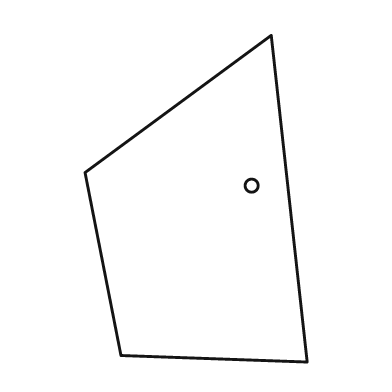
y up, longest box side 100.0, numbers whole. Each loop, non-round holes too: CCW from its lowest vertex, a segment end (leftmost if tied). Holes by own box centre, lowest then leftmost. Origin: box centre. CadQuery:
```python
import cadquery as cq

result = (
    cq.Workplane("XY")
    .moveTo(34.0, -50.0)
    .lineTo(23.0, 50.0)
    .lineTo(-34.0, 8.0)
    .lineTo(-23.0, -48.0)
    .close()
    .moveTo(17.0, 4.0)
    .circle(2.0)
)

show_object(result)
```